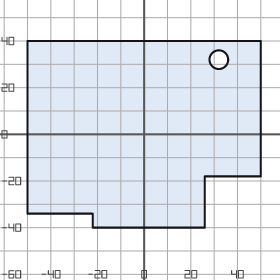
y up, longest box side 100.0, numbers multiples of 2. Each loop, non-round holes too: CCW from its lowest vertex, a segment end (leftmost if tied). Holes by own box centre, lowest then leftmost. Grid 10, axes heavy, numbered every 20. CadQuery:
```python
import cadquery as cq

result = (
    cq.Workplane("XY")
    .moveTo(-22.0, -40.0)
    .lineTo(26.0, -40.0)
    .lineTo(26.0, -18.0)
    .lineTo(50.0, -18.0)
    .lineTo(50.0, 40.0)
    .lineTo(-50.0, 40.0)
    .lineTo(-50.0, -34.0)
    .lineTo(-22.0, -34.0)
    .close()
    .moveTo(32.0, 32.0)
    .circle(4.0)
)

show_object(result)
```